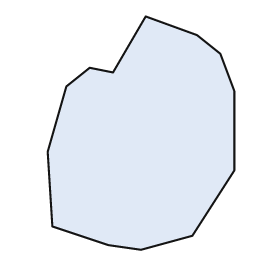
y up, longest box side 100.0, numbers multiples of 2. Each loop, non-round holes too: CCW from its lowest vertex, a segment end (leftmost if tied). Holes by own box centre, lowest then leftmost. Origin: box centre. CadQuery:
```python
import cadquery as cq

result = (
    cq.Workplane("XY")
    .moveTo(0.0, -50.0)
    .lineTo(22.0, -44.0)
    .lineTo(40.0, -16.0)
    .lineTo(40.0, 18.0)
    .lineTo(34.0, 34.0)
    .lineTo(24.0, 42.0)
    .lineTo(2.0, 50.0)
    .lineTo(-12.0, 26.0)
    .lineTo(-22.0, 28.0)
    .lineTo(-32.0, 20.0)
    .lineTo(-40.0, -8.0)
    .lineTo(-38.0, -40.0)
    .lineTo(-14.0, -48.0)
    .close()
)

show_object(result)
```